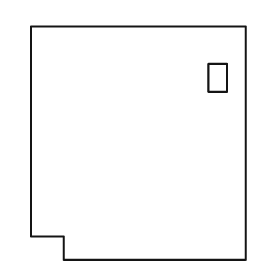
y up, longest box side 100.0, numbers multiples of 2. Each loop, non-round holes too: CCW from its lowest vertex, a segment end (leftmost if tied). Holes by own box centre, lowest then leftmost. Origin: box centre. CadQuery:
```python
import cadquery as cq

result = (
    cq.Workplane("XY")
    .moveTo(-32.0, -50.0)
    .lineTo(46.0, -50.0)
    .lineTo(46.0, 50.0)
    .lineTo(-46.0, 50.0)
    .lineTo(-46.0, -40.0)
    .lineTo(-32.0, -40.0)
    .close()
    .moveTo(30.0, 22.0)
    .lineTo(38.0, 22.0)
    .lineTo(38.0, 34.0)
    .lineTo(30.0, 34.0)
    .close()
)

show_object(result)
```